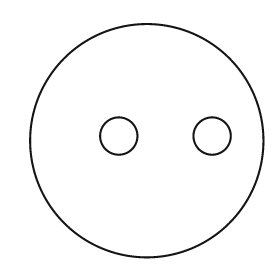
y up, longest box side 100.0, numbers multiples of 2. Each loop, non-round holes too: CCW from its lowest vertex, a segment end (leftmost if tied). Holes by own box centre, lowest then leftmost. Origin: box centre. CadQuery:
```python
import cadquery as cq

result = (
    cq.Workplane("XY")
    .moveTo(0.0, 0.0)
    .circle(50.0)
    .moveTo(-12.0, 2.0)
    .circle(8.0)
    .moveTo(28.0, 2.0)
    .circle(8.0)
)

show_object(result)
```